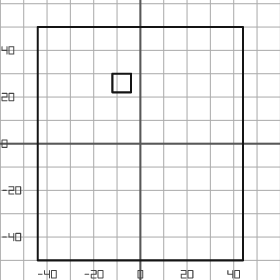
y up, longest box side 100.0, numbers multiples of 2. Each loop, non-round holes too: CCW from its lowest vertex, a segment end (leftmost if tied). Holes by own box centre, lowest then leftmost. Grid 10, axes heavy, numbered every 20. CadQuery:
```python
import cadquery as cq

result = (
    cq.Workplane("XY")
    .moveTo(-44.0, -50.0)
    .lineTo(44.0, -50.0)
    .lineTo(44.0, 50.0)
    .lineTo(-44.0, 50.0)
    .close()
    .moveTo(-12.0, 22.0)
    .lineTo(-4.0, 22.0)
    .lineTo(-4.0, 30.0)
    .lineTo(-12.0, 30.0)
    .close()
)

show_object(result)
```